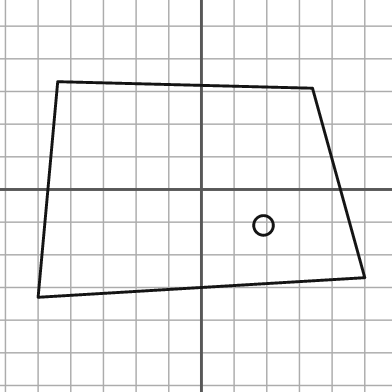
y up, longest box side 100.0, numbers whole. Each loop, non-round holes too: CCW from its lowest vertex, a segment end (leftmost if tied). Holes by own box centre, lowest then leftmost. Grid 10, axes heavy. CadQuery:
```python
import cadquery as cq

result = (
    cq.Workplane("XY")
    .moveTo(-50.0, -33.0)
    .lineTo(50.0, -27.0)
    .lineTo(34.0, 31.0)
    .lineTo(-44.0, 33.0)
    .close()
    .moveTo(19.0, -11.0)
    .circle(3.0)
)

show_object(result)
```